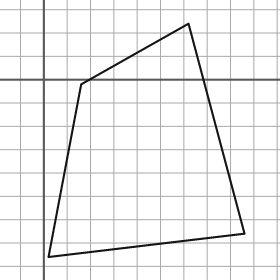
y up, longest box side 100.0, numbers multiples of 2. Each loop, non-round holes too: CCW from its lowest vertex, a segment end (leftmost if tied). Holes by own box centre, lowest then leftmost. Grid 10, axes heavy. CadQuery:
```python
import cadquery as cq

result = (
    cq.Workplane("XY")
    .moveTo(2.0, -76.0)
    .lineTo(86.0, -66.0)
    .lineTo(62.0, 24.0)
    .lineTo(16.0, -2.0)
    .close()
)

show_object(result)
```